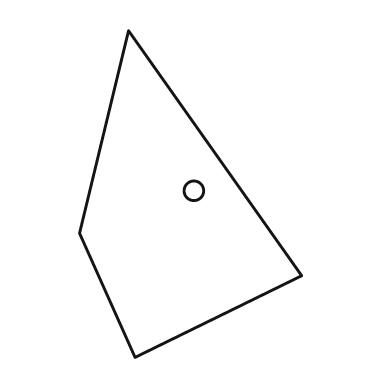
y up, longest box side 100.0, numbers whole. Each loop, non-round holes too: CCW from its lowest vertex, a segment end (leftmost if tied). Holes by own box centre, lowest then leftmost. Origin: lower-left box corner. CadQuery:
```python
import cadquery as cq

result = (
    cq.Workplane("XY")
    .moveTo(17.0, 0.0)
    .lineTo(68.0, 25.0)
    .lineTo(15.0, 100.0)
    .lineTo(0.0, 38.0)
    .close()
    .moveTo(35.0, 51.0)
    .circle(3.0)
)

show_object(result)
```